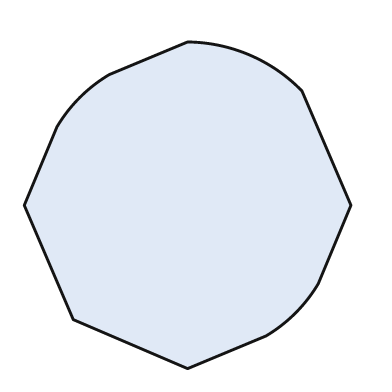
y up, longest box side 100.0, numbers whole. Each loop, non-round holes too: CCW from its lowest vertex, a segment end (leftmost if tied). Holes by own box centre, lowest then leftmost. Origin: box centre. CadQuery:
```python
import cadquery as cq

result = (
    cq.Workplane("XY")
    .moveTo(0.0, -50.0)
    .lineTo(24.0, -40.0)
    .threePointArc((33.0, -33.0), (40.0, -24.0))
    .lineTo(50.0, 0.0)
    .lineTo(35.0, 35.0)
    .threePointArc((19.0, 46.0), (0.0, 50.0))
    .lineTo(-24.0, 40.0)
    .threePointArc((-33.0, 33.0), (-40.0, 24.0))
    .lineTo(-50.0, 0.0)
    .lineTo(-35.0, -35.0)
    .close()
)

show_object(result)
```